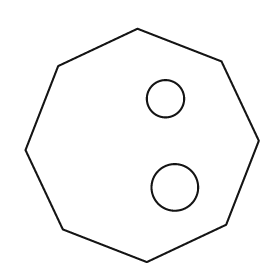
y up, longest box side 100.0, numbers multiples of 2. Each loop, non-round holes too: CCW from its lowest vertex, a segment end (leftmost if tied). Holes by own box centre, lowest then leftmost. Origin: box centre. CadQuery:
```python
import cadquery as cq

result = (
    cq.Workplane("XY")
    .moveTo(2.0, -50.0)
    .lineTo(36.0, -34.0)
    .lineTo(50.0, 2.0)
    .lineTo(34.0, 36.0)
    .lineTo(-2.0, 50.0)
    .lineTo(-36.0, 34.0)
    .lineTo(-50.0, -2.0)
    .lineTo(-34.0, -36.0)
    .close()
    .moveTo(14.0, -18.0)
    .circle(10.0)
    .moveTo(10.0, 20.0)
    .circle(8.0)
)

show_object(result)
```